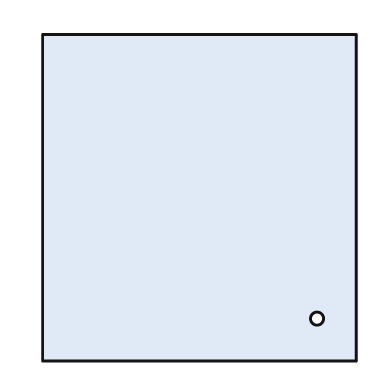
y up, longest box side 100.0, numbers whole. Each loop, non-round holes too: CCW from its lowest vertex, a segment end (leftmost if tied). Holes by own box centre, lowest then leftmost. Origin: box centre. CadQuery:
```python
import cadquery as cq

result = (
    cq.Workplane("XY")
    .moveTo(-48.0, -50.0)
    .lineTo(48.0, -50.0)
    .lineTo(48.0, 50.0)
    .lineTo(-48.0, 50.0)
    .close()
    .moveTo(36.0, -37.0)
    .circle(2.0)
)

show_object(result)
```